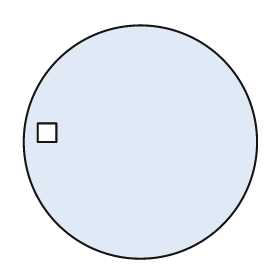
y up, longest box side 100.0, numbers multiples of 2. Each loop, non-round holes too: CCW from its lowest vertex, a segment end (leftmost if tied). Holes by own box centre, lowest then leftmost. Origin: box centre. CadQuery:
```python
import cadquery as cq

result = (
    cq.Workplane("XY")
    .moveTo(0.0, 0.0)
    .circle(50.0)
    .moveTo(-44.0, 0.0)
    .lineTo(-36.0, 0.0)
    .lineTo(-36.0, 8.0)
    .lineTo(-44.0, 8.0)
    .close()
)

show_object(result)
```